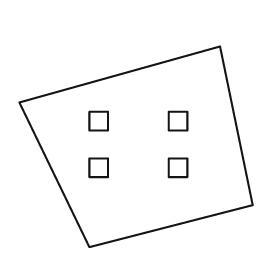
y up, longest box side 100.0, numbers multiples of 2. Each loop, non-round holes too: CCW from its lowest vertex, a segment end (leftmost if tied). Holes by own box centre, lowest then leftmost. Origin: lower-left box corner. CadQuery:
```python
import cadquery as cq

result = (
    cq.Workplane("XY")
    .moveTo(30.0, 0.0)
    .lineTo(100.0, 18.0)
    .lineTo(86.0, 86.0)
    .lineTo(0.0, 62.0)
    .close()
    .moveTo(30.0, 30.0)
    .lineTo(38.0, 30.0)
    .lineTo(38.0, 38.0)
    .lineTo(30.0, 38.0)
    .close()
    .moveTo(64.0, 30.0)
    .lineTo(72.0, 30.0)
    .lineTo(72.0, 38.0)
    .lineTo(64.0, 38.0)
    .close()
    .moveTo(30.0, 50.0)
    .lineTo(38.0, 50.0)
    .lineTo(38.0, 58.0)
    .lineTo(30.0, 58.0)
    .close()
    .moveTo(64.0, 50.0)
    .lineTo(72.0, 50.0)
    .lineTo(72.0, 58.0)
    .lineTo(64.0, 58.0)
    .close()
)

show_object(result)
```